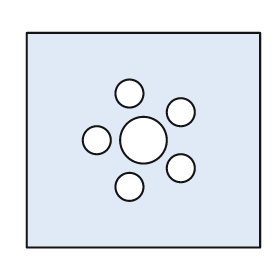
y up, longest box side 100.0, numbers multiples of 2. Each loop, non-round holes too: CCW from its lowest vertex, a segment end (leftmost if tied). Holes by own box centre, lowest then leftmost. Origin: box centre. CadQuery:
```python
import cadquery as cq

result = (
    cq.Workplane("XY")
    .moveTo(-50.0, -46.0)
    .lineTo(50.0, -46.0)
    .lineTo(50.0, 46.0)
    .lineTo(-50.0, 46.0)
    .close()
    .moveTo(-6.0, -20.0)
    .circle(6.0)
    .moveTo(16.0, -12.0)
    .circle(6.0)
    .moveTo(-20.0, 0.0)
    .circle(6.0)
    .moveTo(0.0, 0.0)
    .circle(10.0)
    .moveTo(16.0, 12.0)
    .circle(6.0)
    .moveTo(-6.0, 20.0)
    .circle(6.0)
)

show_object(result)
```